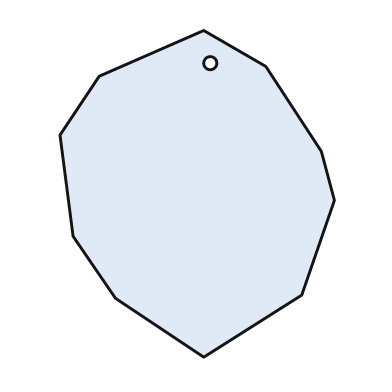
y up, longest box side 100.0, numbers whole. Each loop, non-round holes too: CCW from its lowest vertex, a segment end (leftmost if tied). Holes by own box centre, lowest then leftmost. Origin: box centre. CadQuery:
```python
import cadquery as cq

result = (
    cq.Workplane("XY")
    .moveTo(2.0, -50.0)
    .lineTo(32.0, -31.0)
    .lineTo(42.0, -2.0)
    .lineTo(38.0, 13.0)
    .lineTo(21.0, 39.0)
    .lineTo(2.0, 50.0)
    .lineTo(-30.0, 36.0)
    .lineTo(-42.0, 18.0)
    .lineTo(-38.0, -13.0)
    .lineTo(-25.0, -32.0)
    .close()
    .moveTo(4.0, 40.0)
    .circle(2.0)
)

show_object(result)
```